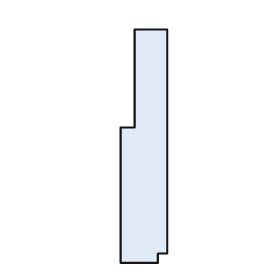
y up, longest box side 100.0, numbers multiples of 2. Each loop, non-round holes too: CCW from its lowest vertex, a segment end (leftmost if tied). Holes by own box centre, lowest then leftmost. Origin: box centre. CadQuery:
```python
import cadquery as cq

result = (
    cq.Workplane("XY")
    .moveTo(-10.0, -50.0)
    .lineTo(6.0, -50.0)
    .lineTo(6.0, -46.0)
    .lineTo(10.0, -46.0)
    .lineTo(10.0, 50.0)
    .lineTo(-4.0, 50.0)
    .lineTo(-4.0, 8.0)
    .lineTo(-10.0, 8.0)
    .close()
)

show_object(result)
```